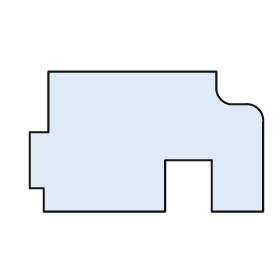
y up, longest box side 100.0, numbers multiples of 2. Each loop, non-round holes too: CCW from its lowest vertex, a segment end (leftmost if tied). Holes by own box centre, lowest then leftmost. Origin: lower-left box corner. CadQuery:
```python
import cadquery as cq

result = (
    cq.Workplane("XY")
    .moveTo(6.0, 0.0)
    .lineTo(58.0, 0.0)
    .lineTo(58.0, 22.0)
    .lineTo(78.0, 22.0)
    .lineTo(78.0, 0.0)
    .lineTo(100.0, 0.0)
    .lineTo(100.0, 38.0)
    .threePointArc((98.0, 44.0), (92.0, 46.0))
    .lineTo(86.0, 46.0)
    .threePointArc((82.0, 48.0), (80.0, 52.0))
    .lineTo(80.0, 60.0)
    .lineTo(8.0, 60.0)
    .lineTo(8.0, 34.0)
    .lineTo(0.0, 34.0)
    .lineTo(0.0, 10.0)
    .lineTo(6.0, 10.0)
    .close()
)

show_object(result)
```